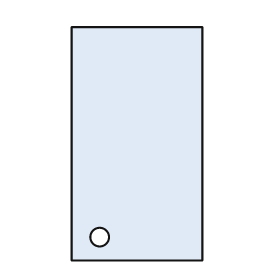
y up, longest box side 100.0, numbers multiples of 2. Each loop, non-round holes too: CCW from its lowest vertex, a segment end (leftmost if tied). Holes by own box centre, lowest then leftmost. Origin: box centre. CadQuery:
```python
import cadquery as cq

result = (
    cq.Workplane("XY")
    .moveTo(-28.0, -50.0)
    .lineTo(28.0, -50.0)
    .lineTo(28.0, 50.0)
    .lineTo(-28.0, 50.0)
    .close()
    .moveTo(-16.0, -40.0)
    .circle(4.0)
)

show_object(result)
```